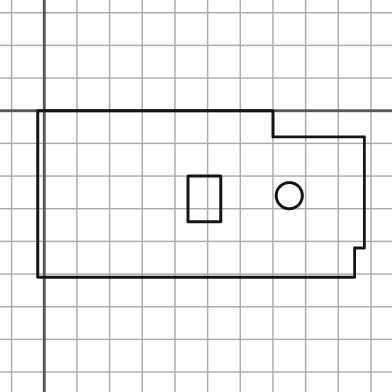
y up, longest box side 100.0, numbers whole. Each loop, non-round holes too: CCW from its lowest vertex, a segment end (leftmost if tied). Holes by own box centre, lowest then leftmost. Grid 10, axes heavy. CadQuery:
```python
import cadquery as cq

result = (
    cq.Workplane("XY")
    .moveTo(-2.0, -51.0)
    .lineTo(95.0, -51.0)
    .lineTo(95.0, -42.0)
    .lineTo(98.0, -42.0)
    .lineTo(98.0, -8.0)
    .lineTo(70.0, -8.0)
    .lineTo(70.0, 0.0)
    .lineTo(-2.0, 0.0)
    .close()
    .moveTo(44.0, -34.0)
    .lineTo(54.0, -34.0)
    .lineTo(54.0, -20.0)
    .lineTo(44.0, -20.0)
    .close()
    .moveTo(75.0, -26.0)
    .circle(4.0)
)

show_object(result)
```